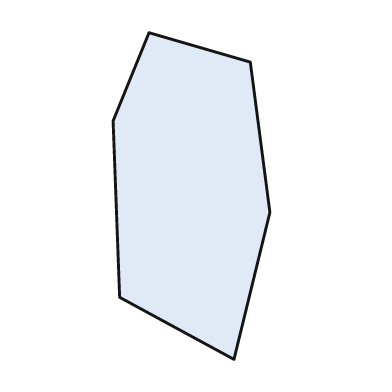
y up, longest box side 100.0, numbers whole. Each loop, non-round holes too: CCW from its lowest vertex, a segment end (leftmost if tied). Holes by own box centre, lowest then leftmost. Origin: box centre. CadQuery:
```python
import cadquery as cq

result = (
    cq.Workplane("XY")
    .moveTo(13.0, -50.0)
    .lineTo(24.0, -5.0)
    .lineTo(18.0, 41.0)
    .lineTo(-13.0, 50.0)
    .lineTo(-24.0, 23.0)
    .lineTo(-22.0, -31.0)
    .close()
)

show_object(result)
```